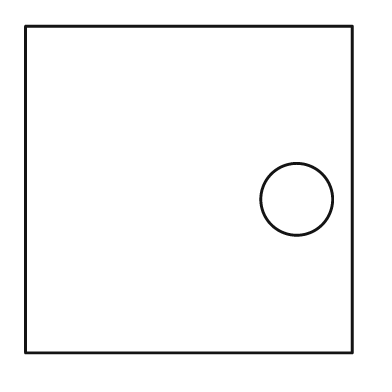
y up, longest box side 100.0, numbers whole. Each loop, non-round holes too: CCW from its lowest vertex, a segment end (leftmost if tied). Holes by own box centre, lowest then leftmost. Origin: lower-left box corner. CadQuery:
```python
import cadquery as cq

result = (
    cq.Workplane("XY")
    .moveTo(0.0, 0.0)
    .lineTo(100.0, 0.0)
    .lineTo(100.0, 100.0)
    .lineTo(0.0, 100.0)
    .close()
    .moveTo(83.0, 47.0)
    .circle(11.0)
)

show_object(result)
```